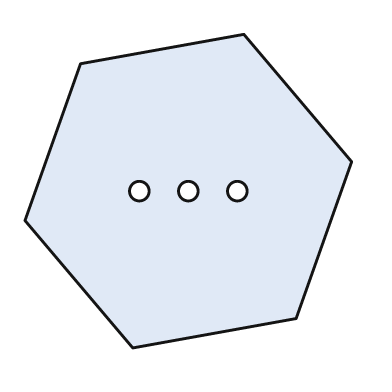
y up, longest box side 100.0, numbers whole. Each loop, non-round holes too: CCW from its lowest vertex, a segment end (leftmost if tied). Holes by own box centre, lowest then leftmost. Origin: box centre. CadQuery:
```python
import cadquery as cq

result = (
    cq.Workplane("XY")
    .moveTo(-17.0, -48.0)
    .lineTo(33.0, -39.0)
    .lineTo(50.0, 9.0)
    .lineTo(17.0, 48.0)
    .lineTo(-33.0, 39.0)
    .lineTo(-50.0, -9.0)
    .close()
    .moveTo(-15.0, 0.0)
    .circle(3.0)
    .moveTo(0.0, 0.0)
    .circle(3.0)
    .moveTo(15.0, 0.0)
    .circle(3.0)
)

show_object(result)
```